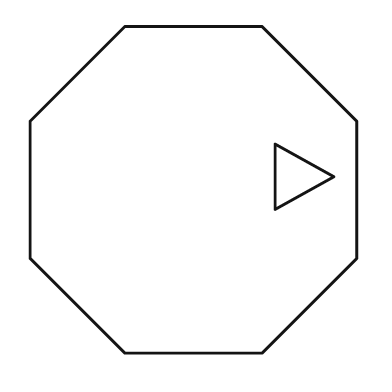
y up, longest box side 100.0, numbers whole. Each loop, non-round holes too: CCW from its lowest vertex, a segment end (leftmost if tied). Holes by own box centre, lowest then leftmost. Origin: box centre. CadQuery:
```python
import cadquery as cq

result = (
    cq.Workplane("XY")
    .moveTo(-21.0, -50.0)
    .lineTo(21.0, -50.0)
    .lineTo(50.0, -21.0)
    .lineTo(50.0, 21.0)
    .lineTo(21.0, 50.0)
    .lineTo(-21.0, 50.0)
    .lineTo(-50.0, 21.0)
    .lineTo(-50.0, -21.0)
    .close()
    .moveTo(25.0, -6.0)
    .lineTo(43.0, 4.0)
    .lineTo(25.0, 14.0)
    .close()
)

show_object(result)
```